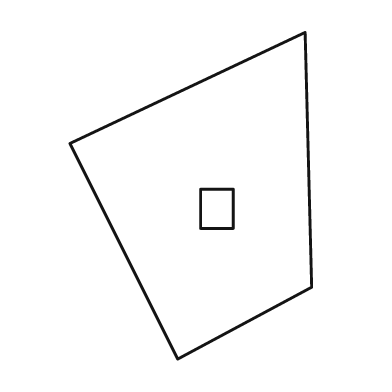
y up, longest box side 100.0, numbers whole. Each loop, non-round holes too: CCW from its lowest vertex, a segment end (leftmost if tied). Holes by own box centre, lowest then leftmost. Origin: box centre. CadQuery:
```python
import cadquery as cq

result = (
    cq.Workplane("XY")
    .moveTo(-4.0, -50.0)
    .lineTo(37.0, -28.0)
    .lineTo(35.0, 50.0)
    .lineTo(-37.0, 16.0)
    .close()
    .moveTo(3.0, -10.0)
    .lineTo(13.0, -10.0)
    .lineTo(13.0, 2.0)
    .lineTo(3.0, 2.0)
    .close()
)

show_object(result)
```